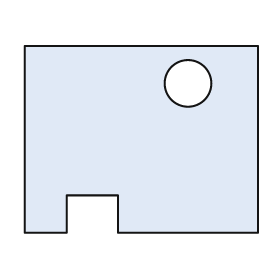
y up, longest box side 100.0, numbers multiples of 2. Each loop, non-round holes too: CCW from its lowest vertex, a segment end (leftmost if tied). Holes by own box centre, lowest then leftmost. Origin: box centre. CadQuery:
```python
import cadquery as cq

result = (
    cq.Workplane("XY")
    .moveTo(-50.0, -40.0)
    .lineTo(-32.0, -40.0)
    .lineTo(-32.0, -24.0)
    .lineTo(-10.0, -24.0)
    .lineTo(-10.0, -40.0)
    .lineTo(50.0, -40.0)
    .lineTo(50.0, 40.0)
    .lineTo(-50.0, 40.0)
    .close()
    .moveTo(20.0, 24.0)
    .circle(10.0)
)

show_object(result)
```